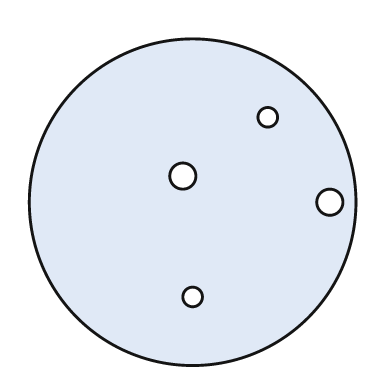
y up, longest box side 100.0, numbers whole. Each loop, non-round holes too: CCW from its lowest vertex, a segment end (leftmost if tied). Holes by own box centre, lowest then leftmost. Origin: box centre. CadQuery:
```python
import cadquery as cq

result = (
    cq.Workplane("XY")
    .moveTo(0.0, 0.0)
    .circle(50.0)
    .moveTo(0.0, -29.0)
    .circle(3.0)
    .moveTo(42.0, 0.0)
    .circle(4.0)
    .moveTo(-3.0, 8.0)
    .circle(4.0)
    .moveTo(23.0, 26.0)
    .circle(3.0)
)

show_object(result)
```